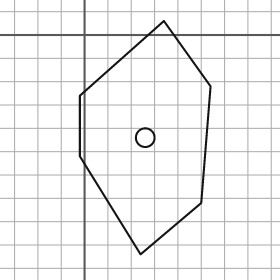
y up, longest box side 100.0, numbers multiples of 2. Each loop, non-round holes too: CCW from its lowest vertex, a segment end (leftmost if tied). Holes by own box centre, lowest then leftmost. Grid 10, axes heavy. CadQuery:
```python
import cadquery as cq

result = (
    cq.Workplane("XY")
    .moveTo(24.0, -94.0)
    .lineTo(50.0, -72.0)
    .lineTo(54.0, -22.0)
    .lineTo(34.0, 6.0)
    .lineTo(-2.0, -26.0)
    .lineTo(-2.0, -52.0)
    .close()
    .moveTo(26.0, -44.0)
    .circle(4.0)
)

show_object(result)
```